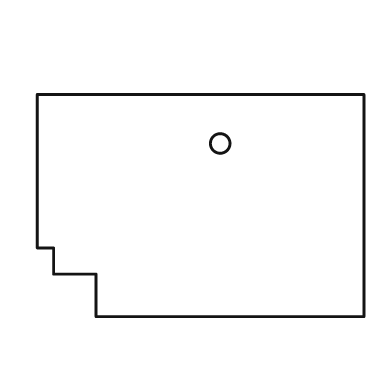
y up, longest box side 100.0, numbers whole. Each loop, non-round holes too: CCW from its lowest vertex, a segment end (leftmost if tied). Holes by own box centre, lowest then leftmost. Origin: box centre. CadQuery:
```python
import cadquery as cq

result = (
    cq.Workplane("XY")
    .moveTo(-32.0, -34.0)
    .lineTo(50.0, -34.0)
    .lineTo(50.0, 34.0)
    .lineTo(-50.0, 34.0)
    .lineTo(-50.0, -13.0)
    .lineTo(-45.0, -13.0)
    .lineTo(-45.0, -21.0)
    .lineTo(-32.0, -21.0)
    .close()
    .moveTo(6.0, 19.0)
    .circle(3.0)
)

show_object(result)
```